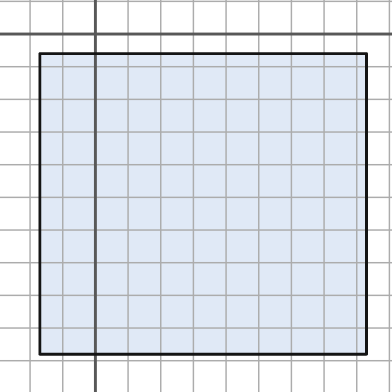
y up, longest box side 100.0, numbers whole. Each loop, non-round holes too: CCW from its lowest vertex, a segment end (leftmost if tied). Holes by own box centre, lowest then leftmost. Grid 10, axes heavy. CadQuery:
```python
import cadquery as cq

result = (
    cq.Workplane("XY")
    .moveTo(-17.0, -98.0)
    .lineTo(83.0, -98.0)
    .lineTo(83.0, -6.0)
    .lineTo(-17.0, -6.0)
    .close()
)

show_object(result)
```